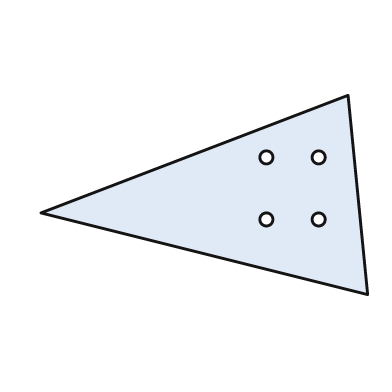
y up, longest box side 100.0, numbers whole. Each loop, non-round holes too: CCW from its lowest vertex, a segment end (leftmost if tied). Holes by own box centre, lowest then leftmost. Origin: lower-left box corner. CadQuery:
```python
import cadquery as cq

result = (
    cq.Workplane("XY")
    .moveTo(100.0, 0.0)
    .lineTo(94.0, 61.0)
    .lineTo(0.0, 25.0)
    .close()
    .moveTo(69.0, 23.0)
    .circle(2.0)
    .moveTo(85.0, 23.0)
    .circle(2.0)
    .moveTo(69.0, 42.0)
    .circle(2.0)
    .moveTo(85.0, 42.0)
    .circle(2.0)
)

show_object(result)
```